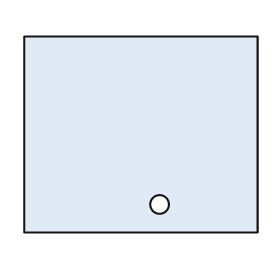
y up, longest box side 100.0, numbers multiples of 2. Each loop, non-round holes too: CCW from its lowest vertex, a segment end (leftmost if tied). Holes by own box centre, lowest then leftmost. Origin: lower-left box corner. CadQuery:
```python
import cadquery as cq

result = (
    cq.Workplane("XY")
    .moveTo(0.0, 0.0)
    .lineTo(100.0, 0.0)
    .lineTo(100.0, 84.0)
    .lineTo(0.0, 84.0)
    .close()
    .moveTo(58.0, 12.0)
    .circle(4.0)
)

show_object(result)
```